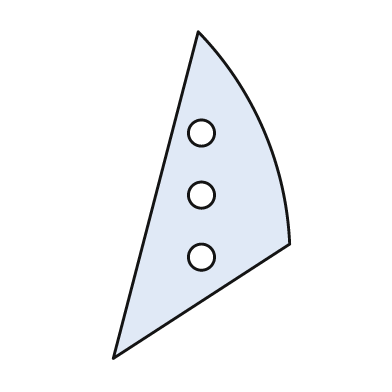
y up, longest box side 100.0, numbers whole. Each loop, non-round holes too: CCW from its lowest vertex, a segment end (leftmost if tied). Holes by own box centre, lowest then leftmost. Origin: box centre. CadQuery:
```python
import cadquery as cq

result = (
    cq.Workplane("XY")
    .moveTo(-27.0, -50.0)
    .lineTo(27.0, -15.0)
    .threePointArc((19.0, 20.0), (-1.0, 50.0))
    .close()
    .moveTo(0.0, -19.0)
    .circle(4.0)
    .moveTo(0.0, 0.0)
    .circle(4.0)
    .moveTo(0.0, 19.0)
    .circle(4.0)
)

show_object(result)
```